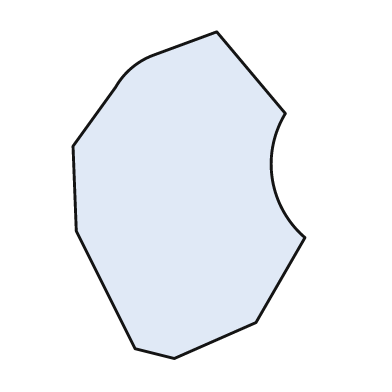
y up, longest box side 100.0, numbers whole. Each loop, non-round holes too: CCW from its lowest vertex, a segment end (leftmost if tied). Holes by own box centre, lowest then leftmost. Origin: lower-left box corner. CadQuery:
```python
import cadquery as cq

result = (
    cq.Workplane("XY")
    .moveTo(31.0, 0.0)
    .lineTo(56.0, 11.0)
    .lineTo(71.0, 37.0)
    .threePointArc((61.0, 55.0), (65.0, 75.0))
    .lineTo(44.0, 100.0)
    .lineTo(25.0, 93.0)
    .threePointArc((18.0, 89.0), (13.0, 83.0))
    .lineTo(0.0, 65.0)
    .lineTo(1.0, 39.0)
    .lineTo(19.0, 3.0)
    .close()
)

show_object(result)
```